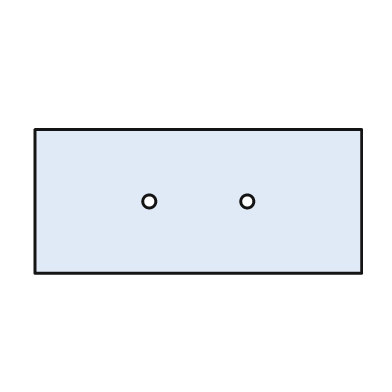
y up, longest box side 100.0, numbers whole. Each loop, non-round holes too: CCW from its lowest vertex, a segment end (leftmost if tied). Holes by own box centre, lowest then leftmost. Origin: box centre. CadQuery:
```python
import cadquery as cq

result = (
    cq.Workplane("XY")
    .moveTo(-50.0, -22.0)
    .lineTo(50.0, -22.0)
    .lineTo(50.0, 22.0)
    .lineTo(-50.0, 22.0)
    .close()
    .moveTo(-15.0, 0.0)
    .circle(2.0)
    .moveTo(15.0, 0.0)
    .circle(2.0)
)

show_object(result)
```